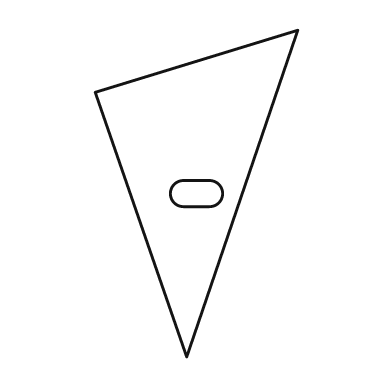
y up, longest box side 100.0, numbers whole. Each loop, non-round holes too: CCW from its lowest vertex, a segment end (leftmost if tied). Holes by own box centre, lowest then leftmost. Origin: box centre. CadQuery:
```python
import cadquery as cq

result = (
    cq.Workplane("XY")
    .moveTo(-3.0, -50.0)
    .lineTo(31.0, 50.0)
    .lineTo(-31.0, 31.0)
    .close()
    .moveTo(-4.0, -4.0)
    .lineTo(4.0, -4.0)
    .threePointArc((8.0, 0.0), (4.0, 4.0))
    .lineTo(-4.0, 4.0)
    .threePointArc((-8.0, 0.0), (-4.0, -4.0))
    .close()
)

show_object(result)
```